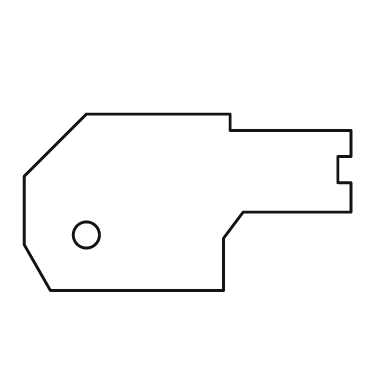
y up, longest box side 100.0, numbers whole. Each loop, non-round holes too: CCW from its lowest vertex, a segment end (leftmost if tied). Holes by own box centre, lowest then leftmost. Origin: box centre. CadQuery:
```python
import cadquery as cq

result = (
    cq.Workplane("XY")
    .moveTo(-42.0, -27.0)
    .lineTo(11.0, -27.0)
    .lineTo(11.0, -11.0)
    .lineTo(17.0, -3.0)
    .lineTo(50.0, -3.0)
    .lineTo(50.0, 6.0)
    .lineTo(46.0, 6.0)
    .lineTo(46.0, 14.0)
    .lineTo(50.0, 14.0)
    .lineTo(50.0, 22.0)
    .lineTo(13.0, 22.0)
    .lineTo(13.0, 27.0)
    .lineTo(-31.0, 27.0)
    .lineTo(-50.0, 8.0)
    .lineTo(-50.0, -13.0)
    .close()
    .moveTo(-31.0, -10.0)
    .circle(4.0)
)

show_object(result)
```